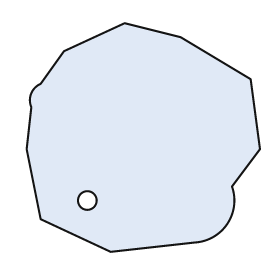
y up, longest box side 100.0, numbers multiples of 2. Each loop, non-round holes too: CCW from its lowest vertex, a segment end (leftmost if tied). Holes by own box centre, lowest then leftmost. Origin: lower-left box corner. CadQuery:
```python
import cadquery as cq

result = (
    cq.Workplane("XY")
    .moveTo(36.0, 0.0)
    .lineTo(72.0, 4.0)
    .threePointArc((86.0, 12.0), (88.0, 28.0))
    .lineTo(100.0, 44.0)
    .lineTo(96.0, 74.0)
    .lineTo(66.0, 92.0)
    .lineTo(42.0, 98.0)
    .lineTo(16.0, 86.0)
    .lineTo(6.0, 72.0)
    .threePointArc((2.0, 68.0), (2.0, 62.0))
    .lineTo(0.0, 44.0)
    .lineTo(6.0, 14.0)
    .close()
    .moveTo(26.0, 22.0)
    .circle(4.0)
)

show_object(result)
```